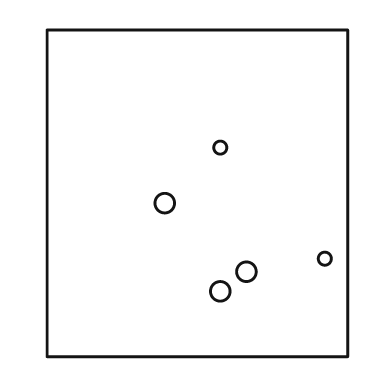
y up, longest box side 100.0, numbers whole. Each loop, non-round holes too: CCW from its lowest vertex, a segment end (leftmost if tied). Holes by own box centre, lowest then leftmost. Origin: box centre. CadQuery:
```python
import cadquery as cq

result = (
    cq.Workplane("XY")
    .moveTo(-46.0, -50.0)
    .lineTo(46.0, -50.0)
    .lineTo(46.0, 50.0)
    .lineTo(-46.0, 50.0)
    .close()
    .moveTo(7.0, -30.0)
    .circle(3.0)
    .moveTo(15.0, -24.0)
    .circle(3.0)
    .moveTo(39.0, -20.0)
    .circle(2.0)
    .moveTo(-10.0, -3.0)
    .circle(3.0)
    .moveTo(7.0, 14.0)
    .circle(2.0)
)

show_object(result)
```